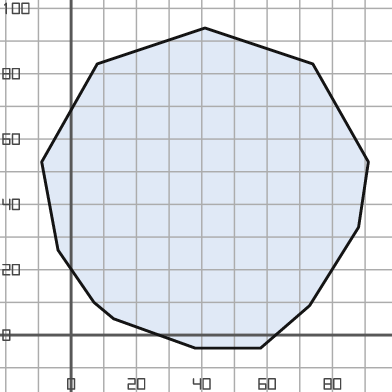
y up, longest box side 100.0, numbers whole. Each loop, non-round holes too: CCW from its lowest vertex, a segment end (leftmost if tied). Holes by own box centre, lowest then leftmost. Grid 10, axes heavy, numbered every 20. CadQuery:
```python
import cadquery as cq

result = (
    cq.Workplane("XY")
    .moveTo(38.0, -4.0)
    .lineTo(58.0, -4.0)
    .lineTo(73.0, 9.0)
    .lineTo(88.0, 33.0)
    .lineTo(91.0, 53.0)
    .lineTo(74.0, 83.0)
    .lineTo(41.0, 94.0)
    .lineTo(8.0, 83.0)
    .lineTo(-9.0, 53.0)
    .lineTo(-4.0, 26.0)
    .lineTo(7.0, 10.0)
    .lineTo(13.0, 5.0)
    .close()
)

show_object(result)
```